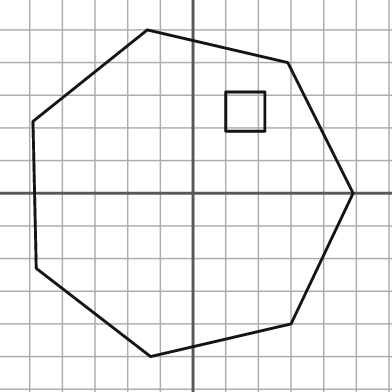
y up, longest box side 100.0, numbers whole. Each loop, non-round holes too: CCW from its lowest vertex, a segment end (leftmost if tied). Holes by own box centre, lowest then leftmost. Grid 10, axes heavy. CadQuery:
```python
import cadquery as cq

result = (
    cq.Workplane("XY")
    .moveTo(-13.0, -50.0)
    .lineTo(30.0, -40.0)
    .lineTo(49.0, 0.0)
    .lineTo(29.0, 40.0)
    .lineTo(-14.0, 50.0)
    .lineTo(-49.0, 22.0)
    .lineTo(-48.0, -23.0)
    .close()
    .moveTo(10.0, 19.0)
    .lineTo(22.0, 19.0)
    .lineTo(22.0, 31.0)
    .lineTo(10.0, 31.0)
    .close()
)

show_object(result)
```